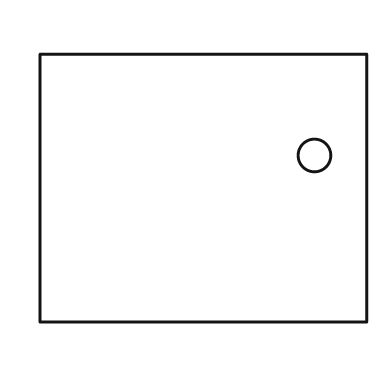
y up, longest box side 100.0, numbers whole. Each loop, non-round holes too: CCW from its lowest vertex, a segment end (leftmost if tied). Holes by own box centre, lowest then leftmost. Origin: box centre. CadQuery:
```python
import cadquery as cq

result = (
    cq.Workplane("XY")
    .moveTo(-50.0, -41.0)
    .lineTo(50.0, -41.0)
    .lineTo(50.0, 41.0)
    .lineTo(-50.0, 41.0)
    .close()
    .moveTo(34.0, 10.0)
    .circle(5.0)
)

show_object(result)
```